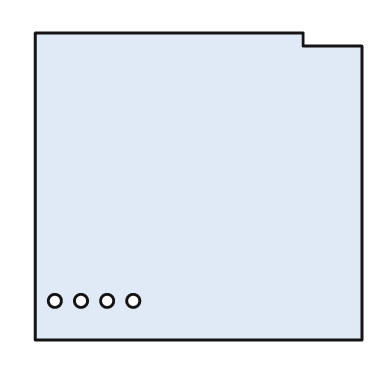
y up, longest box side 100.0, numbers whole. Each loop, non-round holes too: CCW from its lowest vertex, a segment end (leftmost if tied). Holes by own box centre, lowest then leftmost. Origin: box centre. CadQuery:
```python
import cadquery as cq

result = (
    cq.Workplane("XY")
    .moveTo(-50.0, -47.0)
    .lineTo(50.0, -47.0)
    .lineTo(50.0, 43.0)
    .lineTo(32.0, 43.0)
    .lineTo(32.0, 47.0)
    .lineTo(-50.0, 47.0)
    .close()
    .moveTo(-44.0, -35.0)
    .circle(2.0)
    .moveTo(-36.0, -35.0)
    .circle(2.0)
    .moveTo(-28.0, -35.0)
    .circle(2.0)
    .moveTo(-20.0, -35.0)
    .circle(2.0)
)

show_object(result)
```